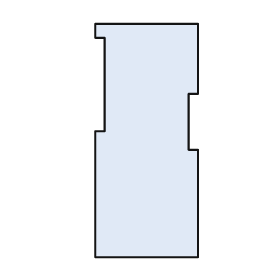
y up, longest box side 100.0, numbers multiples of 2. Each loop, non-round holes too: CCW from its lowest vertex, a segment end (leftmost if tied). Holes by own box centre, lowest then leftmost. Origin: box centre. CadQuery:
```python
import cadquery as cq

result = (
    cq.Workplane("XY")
    .moveTo(-22.0, -50.0)
    .lineTo(22.0, -50.0)
    .lineTo(22.0, -4.0)
    .lineTo(18.0, -4.0)
    .lineTo(18.0, 20.0)
    .lineTo(22.0, 20.0)
    .lineTo(22.0, 50.0)
    .lineTo(-22.0, 50.0)
    .lineTo(-22.0, 44.0)
    .lineTo(-18.0, 44.0)
    .lineTo(-18.0, 4.0)
    .lineTo(-22.0, 4.0)
    .close()
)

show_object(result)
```